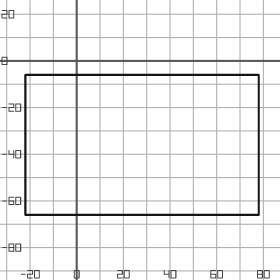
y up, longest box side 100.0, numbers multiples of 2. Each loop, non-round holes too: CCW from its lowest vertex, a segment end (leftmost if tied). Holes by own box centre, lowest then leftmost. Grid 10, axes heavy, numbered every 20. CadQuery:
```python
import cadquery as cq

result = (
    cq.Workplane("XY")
    .moveTo(-22.0, -66.0)
    .lineTo(78.0, -66.0)
    .lineTo(78.0, -6.0)
    .lineTo(-22.0, -6.0)
    .close()
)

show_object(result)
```